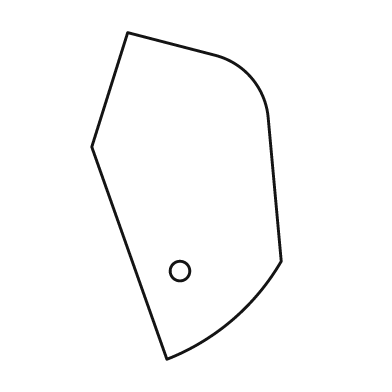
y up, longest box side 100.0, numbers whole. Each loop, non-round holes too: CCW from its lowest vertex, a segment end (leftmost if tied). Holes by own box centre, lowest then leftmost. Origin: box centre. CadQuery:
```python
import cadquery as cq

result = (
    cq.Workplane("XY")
    .moveTo(-6.0, -50.0)
    .threePointArc((14.0, -38.0), (29.0, -20.0))
    .lineTo(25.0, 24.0)
    .threePointArc((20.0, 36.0), (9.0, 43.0))
    .lineTo(-18.0, 50.0)
    .lineTo(-29.0, 15.0)
    .close()
    .moveTo(-2.0, -23.0)
    .circle(3.0)
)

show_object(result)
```